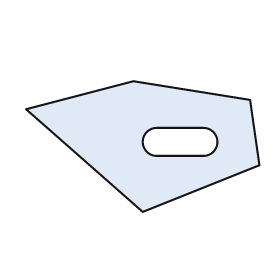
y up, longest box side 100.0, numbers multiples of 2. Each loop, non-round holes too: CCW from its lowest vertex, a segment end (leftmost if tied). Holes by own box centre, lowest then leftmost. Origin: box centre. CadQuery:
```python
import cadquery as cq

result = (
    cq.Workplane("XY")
    .moveTo(0.0, -28.0)
    .lineTo(50.0, -8.0)
    .lineTo(46.0, 20.0)
    .lineTo(-4.0, 28.0)
    .lineTo(-50.0, 16.0)
    .close()
    .moveTo(6.0, -4.0)
    .lineTo(26.0, -4.0)
    .threePointArc((32.0, 2.0), (26.0, 8.0))
    .lineTo(6.0, 8.0)
    .threePointArc((0.0, 2.0), (6.0, -4.0))
    .close()
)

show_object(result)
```